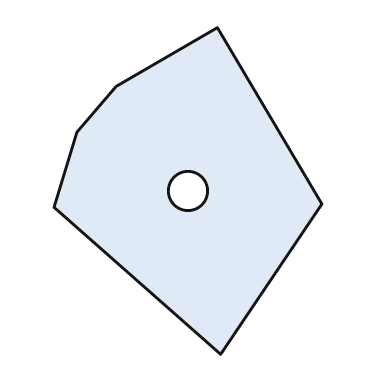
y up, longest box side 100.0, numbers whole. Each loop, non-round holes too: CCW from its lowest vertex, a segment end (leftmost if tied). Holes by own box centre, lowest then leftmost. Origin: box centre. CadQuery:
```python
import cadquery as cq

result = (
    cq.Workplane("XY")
    .moveTo(10.0, -50.0)
    .lineTo(41.0, -4.0)
    .lineTo(9.0, 50.0)
    .lineTo(-22.0, 32.0)
    .lineTo(-34.0, 18.0)
    .lineTo(-41.0, -5.0)
    .close()
    .moveTo(0.0, 0.0)
    .circle(6.0)
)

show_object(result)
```